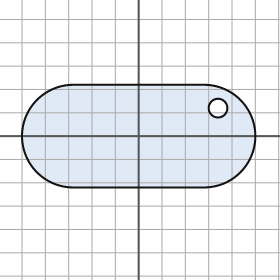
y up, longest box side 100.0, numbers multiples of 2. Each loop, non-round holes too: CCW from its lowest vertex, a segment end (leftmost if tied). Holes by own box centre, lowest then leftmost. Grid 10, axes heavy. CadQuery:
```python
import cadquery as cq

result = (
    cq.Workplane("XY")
    .moveTo(-28.0, -22.0)
    .lineTo(28.0, -22.0)
    .threePointArc((50.0, 0.0), (28.0, 22.0))
    .lineTo(-28.0, 22.0)
    .threePointArc((-50.0, 0.0), (-28.0, -22.0))
    .close()
    .moveTo(34.0, 12.0)
    .circle(4.0)
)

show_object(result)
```